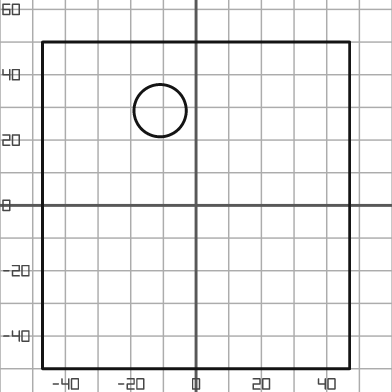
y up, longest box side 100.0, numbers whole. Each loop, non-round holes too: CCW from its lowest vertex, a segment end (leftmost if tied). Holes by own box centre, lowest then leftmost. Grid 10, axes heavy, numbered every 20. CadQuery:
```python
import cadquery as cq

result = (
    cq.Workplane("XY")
    .moveTo(-47.0, -50.0)
    .lineTo(47.0, -50.0)
    .lineTo(47.0, 50.0)
    .lineTo(-47.0, 50.0)
    .close()
    .moveTo(-11.0, 29.0)
    .circle(8.0)
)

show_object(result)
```